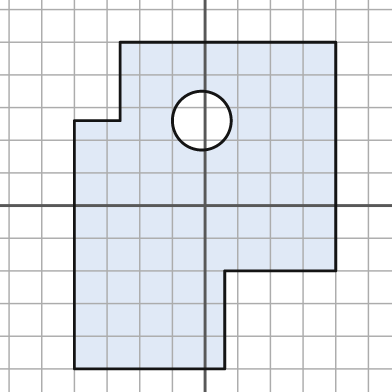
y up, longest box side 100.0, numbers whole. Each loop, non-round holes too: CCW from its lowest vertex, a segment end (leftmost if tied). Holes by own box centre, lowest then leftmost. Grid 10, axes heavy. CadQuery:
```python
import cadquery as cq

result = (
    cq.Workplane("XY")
    .moveTo(-40.0, -50.0)
    .lineTo(6.0, -50.0)
    .lineTo(6.0, -20.0)
    .lineTo(40.0, -20.0)
    .lineTo(40.0, 50.0)
    .lineTo(-26.0, 50.0)
    .lineTo(-26.0, 26.0)
    .lineTo(-40.0, 26.0)
    .close()
    .moveTo(-1.0, 26.0)
    .circle(9.0)
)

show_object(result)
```